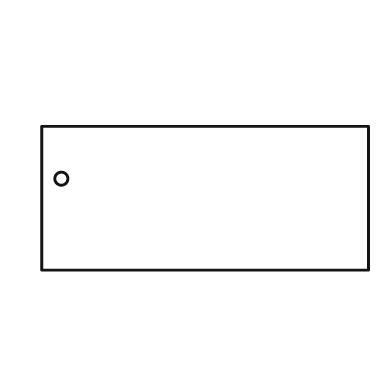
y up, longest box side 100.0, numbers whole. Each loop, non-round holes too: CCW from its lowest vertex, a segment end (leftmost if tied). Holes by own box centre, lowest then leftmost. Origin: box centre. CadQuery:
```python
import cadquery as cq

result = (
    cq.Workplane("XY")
    .moveTo(-50.0, -22.0)
    .lineTo(50.0, -22.0)
    .lineTo(50.0, 22.0)
    .lineTo(-50.0, 22.0)
    .close()
    .moveTo(-44.0, 6.0)
    .circle(2.0)
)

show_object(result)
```